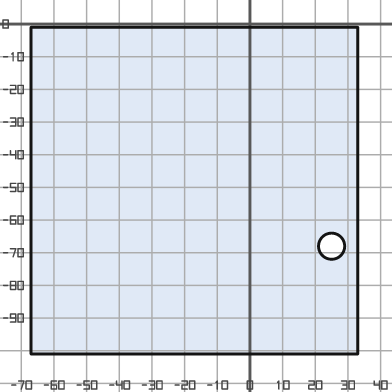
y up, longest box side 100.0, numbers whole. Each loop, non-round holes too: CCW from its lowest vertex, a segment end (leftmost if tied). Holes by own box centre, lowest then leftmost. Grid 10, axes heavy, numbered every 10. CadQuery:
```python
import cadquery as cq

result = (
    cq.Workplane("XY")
    .moveTo(-67.0, -101.0)
    .lineTo(33.0, -101.0)
    .lineTo(33.0, -1.0)
    .lineTo(-67.0, -1.0)
    .close()
    .moveTo(25.0, -68.0)
    .circle(4.0)
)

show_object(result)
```